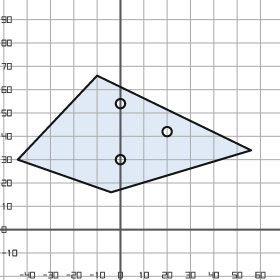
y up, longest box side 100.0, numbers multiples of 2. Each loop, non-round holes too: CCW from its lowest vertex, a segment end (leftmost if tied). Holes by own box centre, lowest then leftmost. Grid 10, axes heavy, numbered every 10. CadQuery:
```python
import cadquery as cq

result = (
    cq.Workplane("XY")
    .moveTo(-4.0, 16.0)
    .lineTo(56.0, 34.0)
    .lineTo(-10.0, 66.0)
    .lineTo(-44.0, 30.0)
    .close()
    .moveTo(0.0, 30.0)
    .circle(2.0)
    .moveTo(20.0, 42.0)
    .circle(2.0)
    .moveTo(0.0, 54.0)
    .circle(2.0)
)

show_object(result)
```